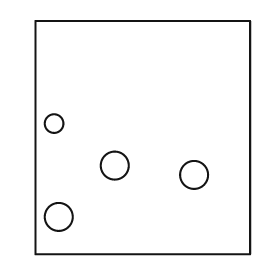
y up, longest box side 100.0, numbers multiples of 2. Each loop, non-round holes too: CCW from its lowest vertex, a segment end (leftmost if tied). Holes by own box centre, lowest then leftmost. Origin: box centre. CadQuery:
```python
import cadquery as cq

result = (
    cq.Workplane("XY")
    .moveTo(-46.0, -50.0)
    .lineTo(46.0, -50.0)
    .lineTo(46.0, 50.0)
    .lineTo(-46.0, 50.0)
    .close()
    .moveTo(-36.0, -34.0)
    .circle(6.0)
    .moveTo(22.0, -16.0)
    .circle(6.0)
    .moveTo(-12.0, -12.0)
    .circle(6.0)
    .moveTo(-38.0, 6.0)
    .circle(4.0)
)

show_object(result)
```